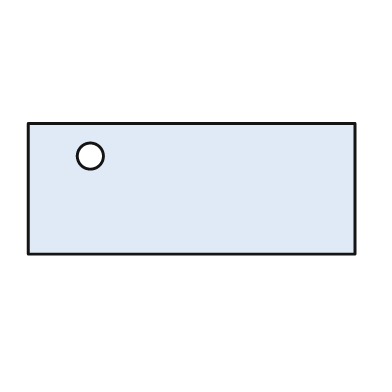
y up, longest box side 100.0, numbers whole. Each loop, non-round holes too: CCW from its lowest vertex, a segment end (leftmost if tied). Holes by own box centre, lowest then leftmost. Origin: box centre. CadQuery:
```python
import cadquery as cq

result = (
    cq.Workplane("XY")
    .moveTo(-50.0, -20.0)
    .lineTo(50.0, -20.0)
    .lineTo(50.0, 20.0)
    .lineTo(-50.0, 20.0)
    .close()
    .moveTo(-31.0, 10.0)
    .circle(4.0)
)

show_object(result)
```